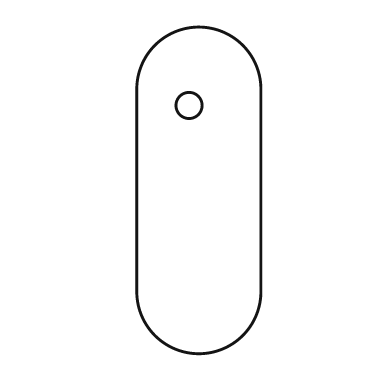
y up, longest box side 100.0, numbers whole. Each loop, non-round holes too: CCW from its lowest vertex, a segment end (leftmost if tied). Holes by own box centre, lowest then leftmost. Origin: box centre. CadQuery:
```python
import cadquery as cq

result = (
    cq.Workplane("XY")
    .moveTo(-19.0, -31.0)
    .threePointArc((0.0, -50.0), (19.0, -31.0))
    .lineTo(19.0, 31.0)
    .threePointArc((0.0, 50.0), (-19.0, 31.0))
    .close()
    .moveTo(-3.0, 26.0)
    .circle(4.0)
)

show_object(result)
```